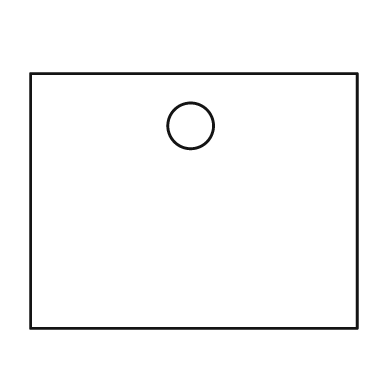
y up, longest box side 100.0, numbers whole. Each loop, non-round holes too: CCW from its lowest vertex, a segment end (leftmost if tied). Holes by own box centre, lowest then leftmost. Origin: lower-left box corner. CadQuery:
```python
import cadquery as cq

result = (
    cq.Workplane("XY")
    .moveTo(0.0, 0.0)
    .lineTo(100.0, 0.0)
    .lineTo(100.0, 78.0)
    .lineTo(0.0, 78.0)
    .close()
    .moveTo(49.0, 62.0)
    .circle(7.0)
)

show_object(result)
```